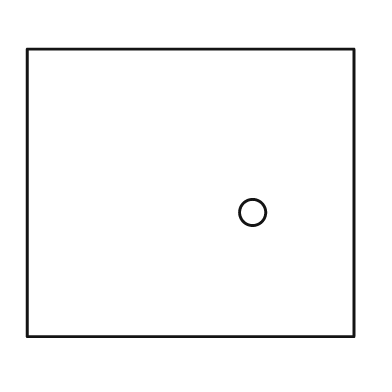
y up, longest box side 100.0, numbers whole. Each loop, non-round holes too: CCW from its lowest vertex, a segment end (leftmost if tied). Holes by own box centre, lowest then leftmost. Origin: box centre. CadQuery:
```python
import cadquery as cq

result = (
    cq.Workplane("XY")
    .moveTo(-50.0, -44.0)
    .lineTo(50.0, -44.0)
    .lineTo(50.0, 44.0)
    .lineTo(-50.0, 44.0)
    .close()
    .moveTo(19.0, -6.0)
    .circle(4.0)
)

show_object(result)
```